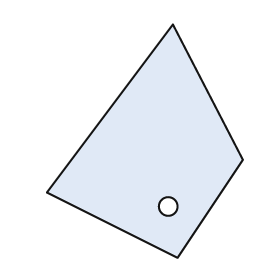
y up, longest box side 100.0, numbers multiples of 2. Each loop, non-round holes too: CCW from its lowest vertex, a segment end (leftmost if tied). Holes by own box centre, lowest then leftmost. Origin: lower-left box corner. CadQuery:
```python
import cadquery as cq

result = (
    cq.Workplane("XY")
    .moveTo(56.0, 0.0)
    .lineTo(84.0, 42.0)
    .lineTo(54.0, 100.0)
    .lineTo(0.0, 28.0)
    .close()
    .moveTo(52.0, 22.0)
    .circle(4.0)
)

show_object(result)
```